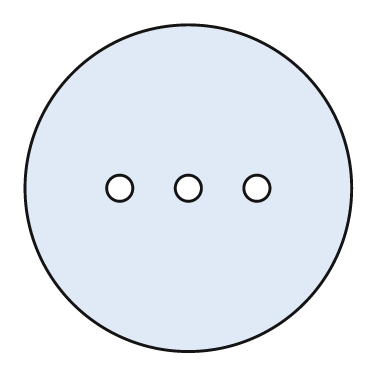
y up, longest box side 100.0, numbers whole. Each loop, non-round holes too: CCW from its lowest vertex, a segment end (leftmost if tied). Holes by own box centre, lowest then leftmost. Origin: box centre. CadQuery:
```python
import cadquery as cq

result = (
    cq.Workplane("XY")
    .moveTo(0.0, 0.0)
    .circle(50.0)
    .moveTo(-21.0, 0.0)
    .circle(4.0)
    .moveTo(0.0, 0.0)
    .circle(4.0)
    .moveTo(21.0, 0.0)
    .circle(4.0)
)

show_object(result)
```